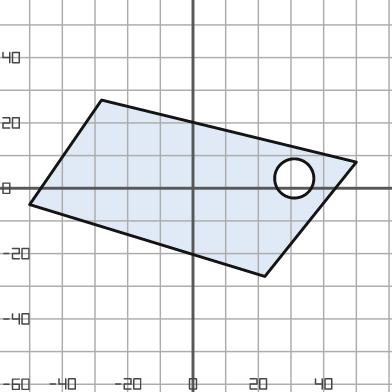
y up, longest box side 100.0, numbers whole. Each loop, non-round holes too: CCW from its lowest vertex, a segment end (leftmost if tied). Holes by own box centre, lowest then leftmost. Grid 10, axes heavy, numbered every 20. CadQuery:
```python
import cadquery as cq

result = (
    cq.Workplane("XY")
    .moveTo(22.0, -27.0)
    .lineTo(50.0, 8.0)
    .lineTo(-28.0, 27.0)
    .lineTo(-50.0, -5.0)
    .close()
    .moveTo(31.0, 3.0)
    .circle(6.0)
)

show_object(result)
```